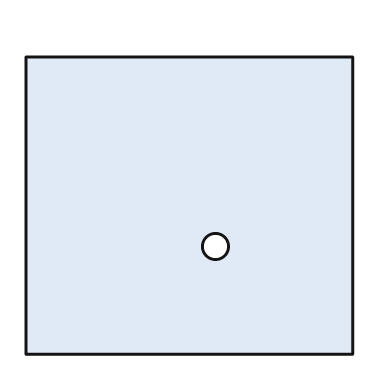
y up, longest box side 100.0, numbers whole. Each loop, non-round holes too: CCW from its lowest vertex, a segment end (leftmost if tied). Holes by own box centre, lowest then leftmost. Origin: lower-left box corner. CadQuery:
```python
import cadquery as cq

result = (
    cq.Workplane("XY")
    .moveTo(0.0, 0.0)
    .lineTo(100.0, 0.0)
    .lineTo(100.0, 91.0)
    .lineTo(0.0, 91.0)
    .close()
    .moveTo(58.0, 33.0)
    .circle(4.0)
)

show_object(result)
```